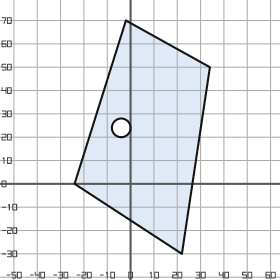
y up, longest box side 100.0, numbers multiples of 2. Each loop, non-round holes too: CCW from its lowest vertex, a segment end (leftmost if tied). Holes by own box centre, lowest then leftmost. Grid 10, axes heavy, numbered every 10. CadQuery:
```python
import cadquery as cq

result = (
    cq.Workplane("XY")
    .moveTo(22.0, -30.0)
    .lineTo(34.0, 50.0)
    .lineTo(-2.0, 70.0)
    .lineTo(-24.0, 0.0)
    .close()
    .moveTo(-4.0, 24.0)
    .circle(4.0)
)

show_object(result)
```